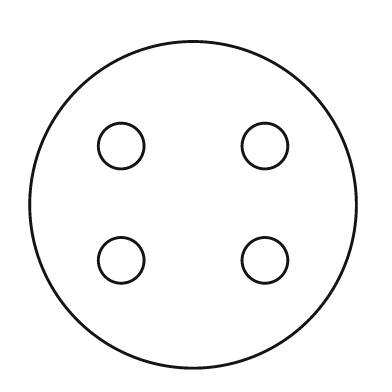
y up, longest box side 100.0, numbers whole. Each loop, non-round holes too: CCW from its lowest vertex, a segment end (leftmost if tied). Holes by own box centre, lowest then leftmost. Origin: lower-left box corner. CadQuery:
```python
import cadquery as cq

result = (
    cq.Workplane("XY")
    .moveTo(50.0, 50.0)
    .circle(50.0)
    .moveTo(28.0, 33.0)
    .circle(7.0)
    .moveTo(72.0, 33.0)
    .circle(7.0)
    .moveTo(28.0, 68.0)
    .circle(7.0)
    .moveTo(72.0, 68.0)
    .circle(7.0)
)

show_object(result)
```